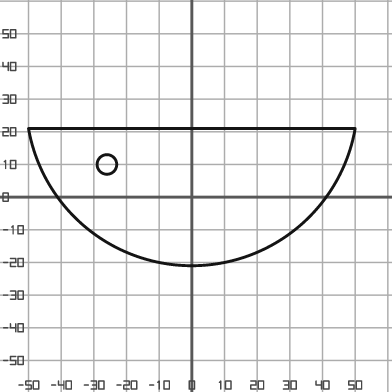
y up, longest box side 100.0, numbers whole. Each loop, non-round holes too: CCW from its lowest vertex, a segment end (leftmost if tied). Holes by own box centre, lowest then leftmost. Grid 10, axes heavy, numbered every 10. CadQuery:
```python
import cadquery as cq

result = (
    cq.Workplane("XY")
    .moveTo(-50.0, 21.0)
    .threePointArc((0.0, -21.0), (50.0, 21.0))
    .close()
    .moveTo(-26.0, 10.0)
    .circle(3.0)
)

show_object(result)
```